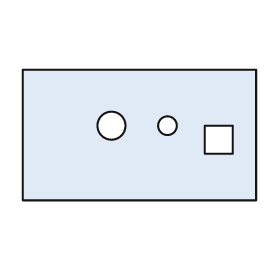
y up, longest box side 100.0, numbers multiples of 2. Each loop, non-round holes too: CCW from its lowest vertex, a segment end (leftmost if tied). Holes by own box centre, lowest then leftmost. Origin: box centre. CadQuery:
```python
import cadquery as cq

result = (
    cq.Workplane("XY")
    .moveTo(-50.0, -28.0)
    .lineTo(50.0, -28.0)
    .lineTo(50.0, 28.0)
    .lineTo(-50.0, 28.0)
    .close()
    .moveTo(28.0, -8.0)
    .lineTo(40.0, -8.0)
    .lineTo(40.0, 4.0)
    .lineTo(28.0, 4.0)
    .close()
    .moveTo(-12.0, 4.0)
    .circle(6.0)
    .moveTo(12.0, 4.0)
    .circle(4.0)
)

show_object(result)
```